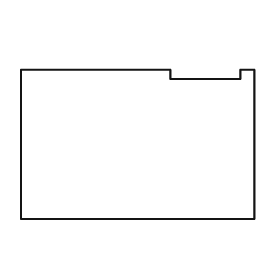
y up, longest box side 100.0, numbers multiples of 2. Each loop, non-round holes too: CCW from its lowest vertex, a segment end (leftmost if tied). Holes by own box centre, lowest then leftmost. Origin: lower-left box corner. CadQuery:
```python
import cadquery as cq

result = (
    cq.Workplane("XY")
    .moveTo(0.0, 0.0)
    .lineTo(100.0, 0.0)
    .lineTo(100.0, 64.0)
    .lineTo(94.0, 64.0)
    .lineTo(94.0, 60.0)
    .lineTo(64.0, 60.0)
    .lineTo(64.0, 64.0)
    .lineTo(0.0, 64.0)
    .close()
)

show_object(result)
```